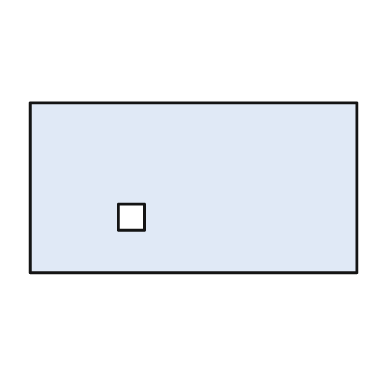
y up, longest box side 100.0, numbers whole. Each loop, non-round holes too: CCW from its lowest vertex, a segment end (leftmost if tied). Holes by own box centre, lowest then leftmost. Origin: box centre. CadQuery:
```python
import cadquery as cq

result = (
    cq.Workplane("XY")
    .moveTo(-50.0, -26.0)
    .lineTo(50.0, -26.0)
    .lineTo(50.0, 26.0)
    .lineTo(-50.0, 26.0)
    .close()
    .moveTo(-23.0, -13.0)
    .lineTo(-15.0, -13.0)
    .lineTo(-15.0, -5.0)
    .lineTo(-23.0, -5.0)
    .close()
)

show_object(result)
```